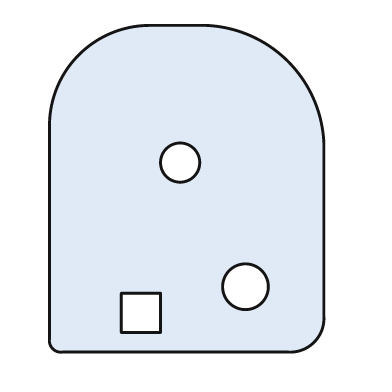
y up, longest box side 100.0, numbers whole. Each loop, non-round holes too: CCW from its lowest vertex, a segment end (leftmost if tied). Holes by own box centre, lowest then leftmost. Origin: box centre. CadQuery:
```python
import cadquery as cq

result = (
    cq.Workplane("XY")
    .moveTo(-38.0, -50.0)
    .lineTo(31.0, -50.0)
    .threePointArc((39.0, -47.0), (42.0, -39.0))
    .lineTo(42.0, 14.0)
    .threePointArc((31.0, 39.0), (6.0, 50.0))
    .lineTo(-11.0, 50.0)
    .threePointArc((-33.0, 41.0), (-42.0, 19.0))
    .lineTo(-42.0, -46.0)
    .threePointArc((-41.0, -49.0), (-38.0, -50.0))
    .close()
    .moveTo(-20.0, -44.0)
    .lineTo(-8.0, -44.0)
    .lineTo(-8.0, -32.0)
    .lineTo(-20.0, -32.0)
    .close()
    .moveTo(18.0, -30.0)
    .circle(7.0)
    .moveTo(-2.0, 8.0)
    .circle(6.0)
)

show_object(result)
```